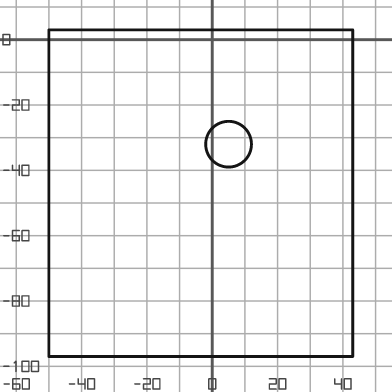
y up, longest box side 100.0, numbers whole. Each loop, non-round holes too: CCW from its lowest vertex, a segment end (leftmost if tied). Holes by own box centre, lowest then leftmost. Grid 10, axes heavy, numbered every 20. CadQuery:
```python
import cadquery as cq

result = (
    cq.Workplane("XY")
    .moveTo(-50.0, -97.0)
    .lineTo(43.0, -97.0)
    .lineTo(43.0, 3.0)
    .lineTo(-50.0, 3.0)
    .close()
    .moveTo(5.0, -32.0)
    .circle(7.0)
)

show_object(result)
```